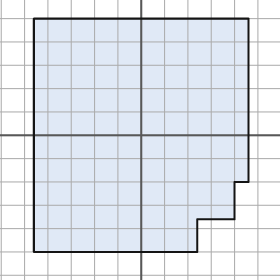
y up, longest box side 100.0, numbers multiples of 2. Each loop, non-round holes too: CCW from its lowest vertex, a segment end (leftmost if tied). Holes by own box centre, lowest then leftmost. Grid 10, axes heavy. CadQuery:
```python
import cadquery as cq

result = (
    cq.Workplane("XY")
    .moveTo(-46.0, -50.0)
    .lineTo(24.0, -50.0)
    .lineTo(24.0, -36.0)
    .lineTo(40.0, -36.0)
    .lineTo(40.0, -20.0)
    .lineTo(46.0, -20.0)
    .lineTo(46.0, 50.0)
    .lineTo(-46.0, 50.0)
    .close()
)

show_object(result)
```